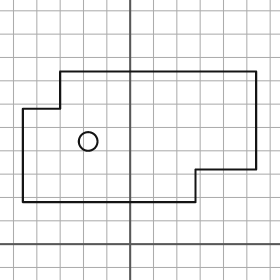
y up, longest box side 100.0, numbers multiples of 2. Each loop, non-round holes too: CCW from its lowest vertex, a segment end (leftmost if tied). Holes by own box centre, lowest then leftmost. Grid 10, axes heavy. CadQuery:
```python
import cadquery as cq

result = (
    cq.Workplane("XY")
    .moveTo(-46.0, 18.0)
    .lineTo(28.0, 18.0)
    .lineTo(28.0, 32.0)
    .lineTo(54.0, 32.0)
    .lineTo(54.0, 74.0)
    .lineTo(-30.0, 74.0)
    .lineTo(-30.0, 58.0)
    .lineTo(-46.0, 58.0)
    .close()
    .moveTo(-18.0, 44.0)
    .circle(4.0)
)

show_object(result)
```